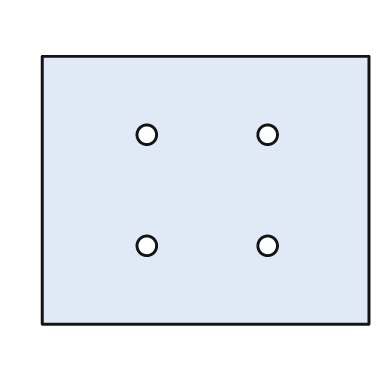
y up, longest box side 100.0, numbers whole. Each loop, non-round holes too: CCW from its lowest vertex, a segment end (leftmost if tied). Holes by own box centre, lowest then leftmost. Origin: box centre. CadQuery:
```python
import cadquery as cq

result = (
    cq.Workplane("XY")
    .moveTo(-50.0, -41.0)
    .lineTo(50.0, -41.0)
    .lineTo(50.0, 41.0)
    .lineTo(-50.0, 41.0)
    .close()
    .moveTo(-18.0, -17.0)
    .circle(3.0)
    .moveTo(19.0, -17.0)
    .circle(3.0)
    .moveTo(-18.0, 17.0)
    .circle(3.0)
    .moveTo(19.0, 17.0)
    .circle(3.0)
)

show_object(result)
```